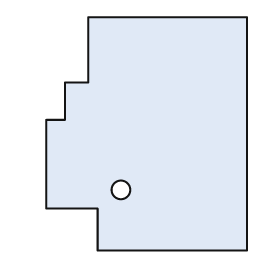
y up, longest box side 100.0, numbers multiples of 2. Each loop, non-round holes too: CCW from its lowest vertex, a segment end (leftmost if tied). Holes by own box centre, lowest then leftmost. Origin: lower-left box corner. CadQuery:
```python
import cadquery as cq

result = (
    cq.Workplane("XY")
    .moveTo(22.0, 0.0)
    .lineTo(86.0, 0.0)
    .lineTo(86.0, 100.0)
    .lineTo(18.0, 100.0)
    .lineTo(18.0, 72.0)
    .lineTo(8.0, 72.0)
    .lineTo(8.0, 56.0)
    .lineTo(0.0, 56.0)
    .lineTo(0.0, 18.0)
    .lineTo(22.0, 18.0)
    .close()
    .moveTo(32.0, 26.0)
    .circle(4.0)
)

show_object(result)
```